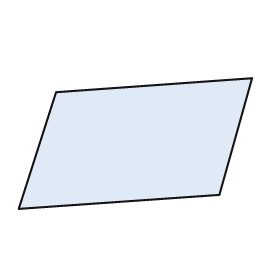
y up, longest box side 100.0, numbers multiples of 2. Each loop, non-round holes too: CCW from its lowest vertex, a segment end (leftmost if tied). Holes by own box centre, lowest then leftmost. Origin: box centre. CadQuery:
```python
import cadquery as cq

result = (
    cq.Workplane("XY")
    .moveTo(-50.0, -28.0)
    .lineTo(36.0, -22.0)
    .lineTo(50.0, 28.0)
    .lineTo(-34.0, 22.0)
    .close()
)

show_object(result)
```